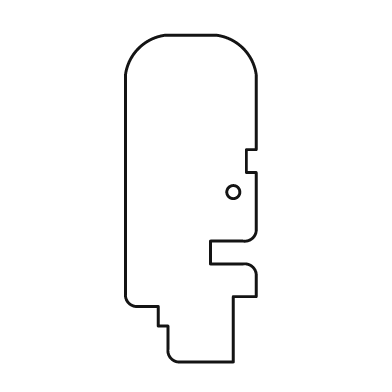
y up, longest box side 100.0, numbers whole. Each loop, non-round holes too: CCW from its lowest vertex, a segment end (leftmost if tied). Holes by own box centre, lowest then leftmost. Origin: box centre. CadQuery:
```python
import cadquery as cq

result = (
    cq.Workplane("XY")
    .moveTo(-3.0, -50.0)
    .lineTo(13.0, -50.0)
    .lineTo(13.0, -30.0)
    .lineTo(20.0, -30.0)
    .lineTo(20.0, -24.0)
    .threePointArc((19.0, -21.0), (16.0, -20.0))
    .lineTo(6.0, -20.0)
    .lineTo(6.0, -13.0)
    .lineTo(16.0, -13.0)
    .threePointArc((19.0, -12.0), (20.0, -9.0))
    .lineTo(20.0, 8.0)
    .lineTo(17.0, 8.0)
    .lineTo(17.0, 15.0)
    .lineTo(20.0, 15.0)
    .lineTo(20.0, 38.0)
    .threePointArc((16.0, 46.0), (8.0, 50.0))
    .lineTo(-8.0, 50.0)
    .threePointArc((-16.0, 46.0), (-20.0, 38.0))
    .lineTo(-20.0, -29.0)
    .threePointArc((-19.0, -32.0), (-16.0, -33.0))
    .lineTo(-10.0, -33.0)
    .lineTo(-10.0, -39.0)
    .lineTo(-7.0, -39.0)
    .lineTo(-7.0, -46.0)
    .threePointArc((-6.0, -49.0), (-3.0, -50.0))
    .close()
    .moveTo(13.0, 2.0)
    .circle(2.0)
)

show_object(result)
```